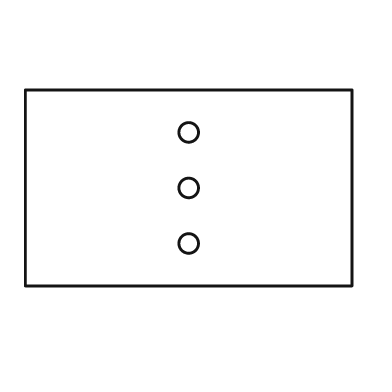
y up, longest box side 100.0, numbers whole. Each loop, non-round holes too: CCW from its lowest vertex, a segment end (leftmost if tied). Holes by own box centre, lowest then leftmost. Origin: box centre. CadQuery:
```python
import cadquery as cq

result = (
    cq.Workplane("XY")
    .moveTo(-50.0, -30.0)
    .lineTo(50.0, -30.0)
    .lineTo(50.0, 30.0)
    .lineTo(-50.0, 30.0)
    .close()
    .moveTo(0.0, -17.0)
    .circle(3.0)
    .moveTo(0.0, 0.0)
    .circle(3.0)
    .moveTo(0.0, 17.0)
    .circle(3.0)
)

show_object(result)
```